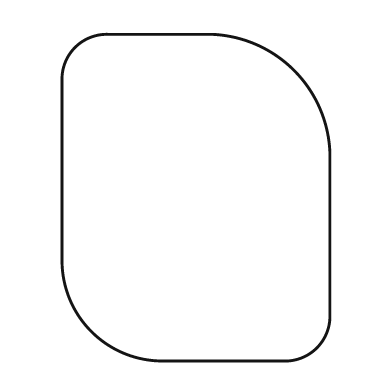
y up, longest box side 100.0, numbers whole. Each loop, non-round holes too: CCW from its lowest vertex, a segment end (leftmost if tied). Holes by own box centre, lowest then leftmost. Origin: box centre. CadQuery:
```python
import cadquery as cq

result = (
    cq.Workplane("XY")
    .moveTo(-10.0, -50.0)
    .lineTo(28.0, -50.0)
    .threePointArc((37.0, -46.0), (41.0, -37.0))
    .lineTo(41.0, 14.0)
    .threePointArc((30.0, 39.0), (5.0, 50.0))
    .lineTo(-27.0, 50.0)
    .threePointArc((-37.0, 46.0), (-41.0, 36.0))
    .lineTo(-41.0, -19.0)
    .threePointArc((-32.0, -41.0), (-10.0, -50.0))
    .close()
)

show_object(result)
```